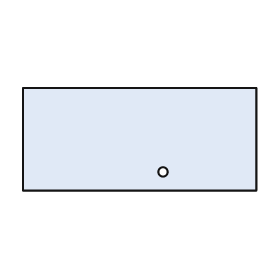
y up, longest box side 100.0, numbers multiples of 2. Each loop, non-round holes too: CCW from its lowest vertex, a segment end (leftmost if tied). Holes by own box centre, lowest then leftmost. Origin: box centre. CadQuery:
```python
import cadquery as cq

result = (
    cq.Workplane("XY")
    .moveTo(-50.0, -22.0)
    .lineTo(50.0, -22.0)
    .lineTo(50.0, 22.0)
    .lineTo(-50.0, 22.0)
    .close()
    .moveTo(10.0, -14.0)
    .circle(2.0)
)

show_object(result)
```